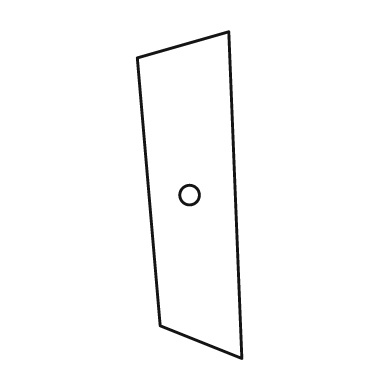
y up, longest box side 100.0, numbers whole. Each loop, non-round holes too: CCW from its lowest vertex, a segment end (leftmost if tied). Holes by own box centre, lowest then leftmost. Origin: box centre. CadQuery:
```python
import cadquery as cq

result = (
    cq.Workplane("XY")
    .moveTo(16.0, -50.0)
    .lineTo(12.0, 50.0)
    .lineTo(-16.0, 42.0)
    .lineTo(-9.0, -40.0)
    .close()
    .moveTo(0.0, 0.0)
    .circle(3.0)
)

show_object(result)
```